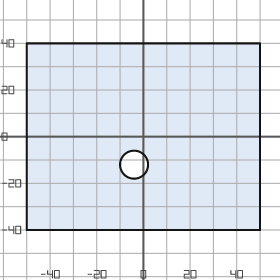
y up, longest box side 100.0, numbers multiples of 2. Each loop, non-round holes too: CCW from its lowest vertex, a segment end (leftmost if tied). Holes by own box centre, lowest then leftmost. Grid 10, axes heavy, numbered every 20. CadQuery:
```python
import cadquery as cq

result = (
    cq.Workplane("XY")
    .moveTo(-50.0, -40.0)
    .lineTo(50.0, -40.0)
    .lineTo(50.0, 40.0)
    .lineTo(-50.0, 40.0)
    .close()
    .moveTo(-4.0, -12.0)
    .circle(6.0)
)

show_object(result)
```